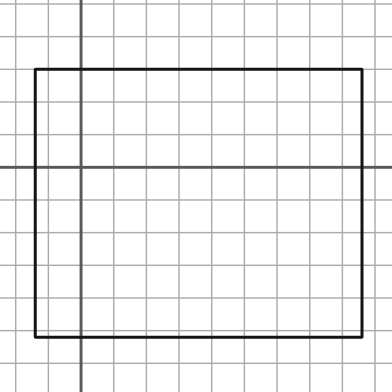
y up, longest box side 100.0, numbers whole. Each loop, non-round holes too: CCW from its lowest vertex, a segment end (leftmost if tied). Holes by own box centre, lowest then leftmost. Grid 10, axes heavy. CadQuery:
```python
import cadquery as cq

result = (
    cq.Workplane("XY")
    .moveTo(-14.0, -52.0)
    .lineTo(86.0, -52.0)
    .lineTo(86.0, 30.0)
    .lineTo(-14.0, 30.0)
    .close()
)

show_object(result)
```